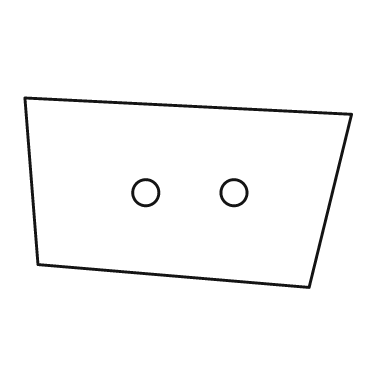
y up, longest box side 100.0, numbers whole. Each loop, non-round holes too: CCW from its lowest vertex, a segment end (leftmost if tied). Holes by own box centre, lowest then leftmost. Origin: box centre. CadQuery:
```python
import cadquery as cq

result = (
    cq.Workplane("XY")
    .moveTo(37.0, -29.0)
    .lineTo(50.0, 24.0)
    .lineTo(-50.0, 29.0)
    .lineTo(-46.0, -22.0)
    .close()
    .moveTo(-13.0, 0.0)
    .circle(4.0)
    .moveTo(14.0, 0.0)
    .circle(4.0)
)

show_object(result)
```